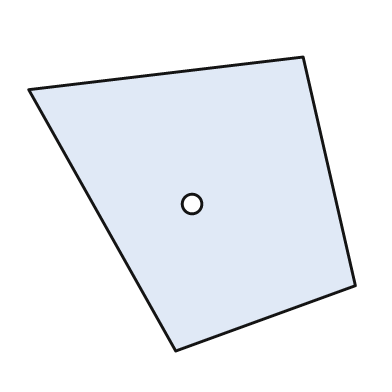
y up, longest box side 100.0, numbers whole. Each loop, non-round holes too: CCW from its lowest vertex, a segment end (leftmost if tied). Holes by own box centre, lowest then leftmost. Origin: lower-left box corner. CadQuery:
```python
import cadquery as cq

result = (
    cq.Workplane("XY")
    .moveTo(45.0, 0.0)
    .lineTo(100.0, 20.0)
    .lineTo(84.0, 90.0)
    .lineTo(0.0, 80.0)
    .close()
    .moveTo(50.0, 45.0)
    .circle(3.0)
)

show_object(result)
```